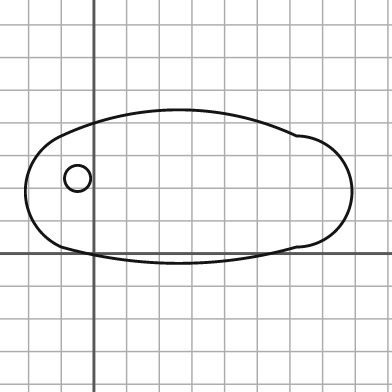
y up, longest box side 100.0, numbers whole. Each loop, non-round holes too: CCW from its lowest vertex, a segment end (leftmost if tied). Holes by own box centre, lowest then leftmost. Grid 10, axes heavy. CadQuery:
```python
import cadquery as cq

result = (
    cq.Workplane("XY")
    .moveTo(-10.0, 2.0)
    .threePointArc((26.0, -3.0), (62.0, 2.0))
    .threePointArc((79.0, 19.0), (62.0, 36.0))
    .threePointArc((26.0, 44.0), (-10.0, 36.0))
    .threePointArc((-21.0, 19.0), (-10.0, 2.0))
    .close()
    .moveTo(-5.0, 23.0)
    .circle(4.0)
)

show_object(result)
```